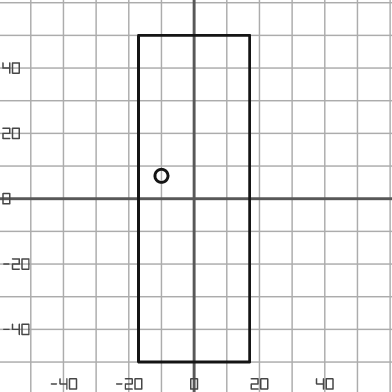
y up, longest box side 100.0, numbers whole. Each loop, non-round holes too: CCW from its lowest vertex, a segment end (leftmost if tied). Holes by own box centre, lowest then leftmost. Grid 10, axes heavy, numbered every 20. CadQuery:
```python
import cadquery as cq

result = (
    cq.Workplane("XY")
    .moveTo(-17.0, -50.0)
    .lineTo(17.0, -50.0)
    .lineTo(17.0, 50.0)
    .lineTo(-17.0, 50.0)
    .close()
    .moveTo(-10.0, 7.0)
    .circle(2.0)
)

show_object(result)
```